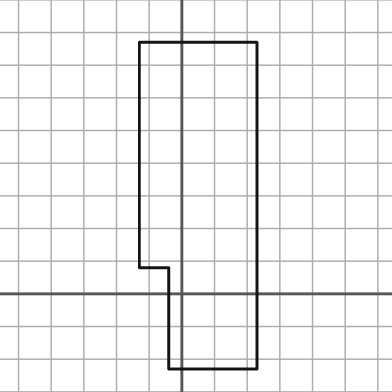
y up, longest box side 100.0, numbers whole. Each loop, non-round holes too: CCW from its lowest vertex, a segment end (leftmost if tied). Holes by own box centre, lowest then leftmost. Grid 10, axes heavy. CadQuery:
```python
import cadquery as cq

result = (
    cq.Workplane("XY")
    .moveTo(-4.0, -23.0)
    .lineTo(23.0, -23.0)
    .lineTo(23.0, 77.0)
    .lineTo(-13.0, 77.0)
    .lineTo(-13.0, 8.0)
    .lineTo(-4.0, 8.0)
    .close()
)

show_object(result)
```